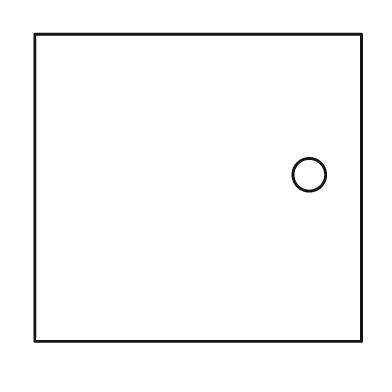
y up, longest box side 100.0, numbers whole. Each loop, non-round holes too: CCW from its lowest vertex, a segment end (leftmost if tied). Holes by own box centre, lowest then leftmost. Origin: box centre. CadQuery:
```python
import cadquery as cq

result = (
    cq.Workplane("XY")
    .moveTo(-50.0, -47.0)
    .lineTo(50.0, -47.0)
    .lineTo(50.0, 47.0)
    .lineTo(-50.0, 47.0)
    .close()
    .moveTo(34.0, 4.0)
    .circle(5.0)
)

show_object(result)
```